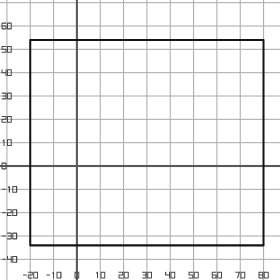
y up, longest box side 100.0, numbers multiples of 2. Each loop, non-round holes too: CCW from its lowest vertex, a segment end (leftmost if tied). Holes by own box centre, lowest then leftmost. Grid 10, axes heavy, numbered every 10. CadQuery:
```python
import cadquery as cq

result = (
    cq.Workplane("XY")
    .moveTo(-20.0, -34.0)
    .lineTo(80.0, -34.0)
    .lineTo(80.0, 54.0)
    .lineTo(-20.0, 54.0)
    .close()
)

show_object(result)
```